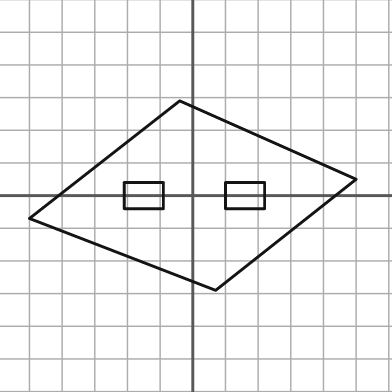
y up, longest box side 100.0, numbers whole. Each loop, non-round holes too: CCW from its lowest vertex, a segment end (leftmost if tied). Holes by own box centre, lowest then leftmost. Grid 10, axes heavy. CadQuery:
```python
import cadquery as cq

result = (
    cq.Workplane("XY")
    .moveTo(7.0, -29.0)
    .lineTo(50.0, 5.0)
    .lineTo(-4.0, 29.0)
    .lineTo(-50.0, -7.0)
    .close()
    .moveTo(-21.0, -4.0)
    .lineTo(-9.0, -4.0)
    .lineTo(-9.0, 4.0)
    .lineTo(-21.0, 4.0)
    .close()
    .moveTo(10.0, -4.0)
    .lineTo(22.0, -4.0)
    .lineTo(22.0, 4.0)
    .lineTo(10.0, 4.0)
    .close()
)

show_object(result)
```